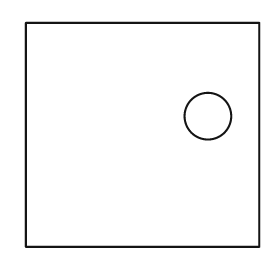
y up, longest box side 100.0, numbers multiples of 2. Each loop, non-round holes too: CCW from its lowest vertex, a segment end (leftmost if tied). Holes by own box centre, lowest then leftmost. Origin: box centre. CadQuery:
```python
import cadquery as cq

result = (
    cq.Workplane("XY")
    .moveTo(-50.0, -48.0)
    .lineTo(50.0, -48.0)
    .lineTo(50.0, 48.0)
    .lineTo(-50.0, 48.0)
    .close()
    .moveTo(28.0, 8.0)
    .circle(10.0)
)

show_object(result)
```